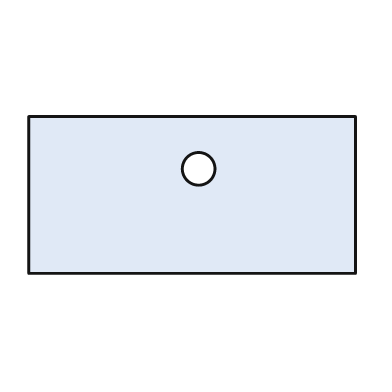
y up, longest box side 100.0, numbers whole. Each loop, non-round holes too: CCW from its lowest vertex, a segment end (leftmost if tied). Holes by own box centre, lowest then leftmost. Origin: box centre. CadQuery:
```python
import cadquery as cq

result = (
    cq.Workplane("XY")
    .moveTo(-50.0, -24.0)
    .lineTo(50.0, -24.0)
    .lineTo(50.0, 24.0)
    .lineTo(-50.0, 24.0)
    .close()
    .moveTo(2.0, 8.0)
    .circle(5.0)
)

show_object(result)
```